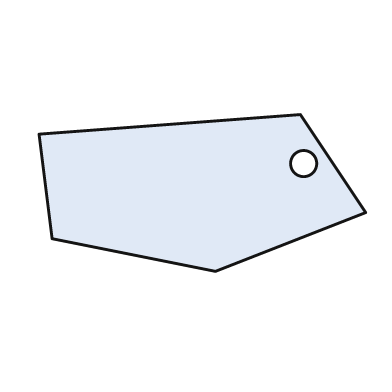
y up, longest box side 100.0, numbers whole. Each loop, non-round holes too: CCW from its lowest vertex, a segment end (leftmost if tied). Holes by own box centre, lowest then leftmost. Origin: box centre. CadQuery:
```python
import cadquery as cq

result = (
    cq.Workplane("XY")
    .moveTo(4.0, -24.0)
    .lineTo(50.0, -6.0)
    .lineTo(30.0, 24.0)
    .lineTo(-50.0, 18.0)
    .lineTo(-46.0, -14.0)
    .close()
    .moveTo(31.0, 9.0)
    .circle(4.0)
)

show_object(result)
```